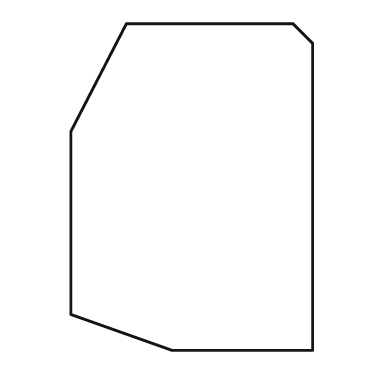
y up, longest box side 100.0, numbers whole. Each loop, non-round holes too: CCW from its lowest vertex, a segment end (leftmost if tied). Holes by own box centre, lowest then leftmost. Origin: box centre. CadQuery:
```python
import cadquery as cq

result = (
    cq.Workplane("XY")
    .moveTo(-6.0, -50.0)
    .lineTo(37.0, -50.0)
    .lineTo(37.0, 44.0)
    .lineTo(31.0, 50.0)
    .lineTo(-20.0, 50.0)
    .lineTo(-37.0, 17.0)
    .lineTo(-37.0, -39.0)
    .close()
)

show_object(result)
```